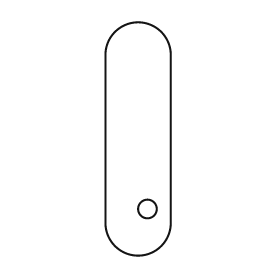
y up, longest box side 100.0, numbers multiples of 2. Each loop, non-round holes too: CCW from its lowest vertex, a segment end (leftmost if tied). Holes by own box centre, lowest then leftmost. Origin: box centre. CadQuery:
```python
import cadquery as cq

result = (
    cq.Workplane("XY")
    .moveTo(-14.0, -36.0)
    .threePointArc((0.0, -50.0), (14.0, -36.0))
    .lineTo(14.0, 36.0)
    .threePointArc((0.0, 50.0), (-14.0, 36.0))
    .close()
    .moveTo(4.0, -30.0)
    .circle(4.0)
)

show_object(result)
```